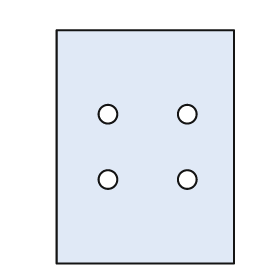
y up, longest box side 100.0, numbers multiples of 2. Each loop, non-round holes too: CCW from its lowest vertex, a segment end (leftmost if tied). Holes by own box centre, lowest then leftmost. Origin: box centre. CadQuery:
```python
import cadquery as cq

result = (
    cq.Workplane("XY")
    .moveTo(-38.0, -50.0)
    .lineTo(38.0, -50.0)
    .lineTo(38.0, 50.0)
    .lineTo(-38.0, 50.0)
    .close()
    .moveTo(-16.0, -14.0)
    .circle(4.0)
    .moveTo(18.0, -14.0)
    .circle(4.0)
    .moveTo(-16.0, 14.0)
    .circle(4.0)
    .moveTo(18.0, 14.0)
    .circle(4.0)
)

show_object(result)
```